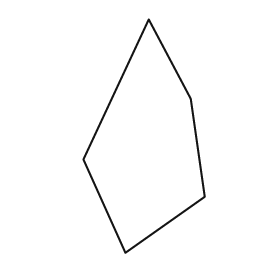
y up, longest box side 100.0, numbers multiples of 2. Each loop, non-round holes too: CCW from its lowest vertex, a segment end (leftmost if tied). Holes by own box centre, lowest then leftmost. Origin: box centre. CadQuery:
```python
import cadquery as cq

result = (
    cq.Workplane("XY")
    .moveTo(-8.0, -50.0)
    .lineTo(26.0, -26.0)
    .lineTo(20.0, 16.0)
    .lineTo(2.0, 50.0)
    .lineTo(-26.0, -10.0)
    .close()
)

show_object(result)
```